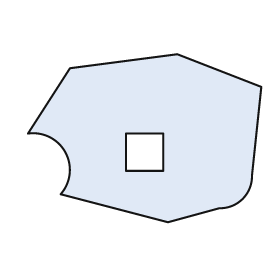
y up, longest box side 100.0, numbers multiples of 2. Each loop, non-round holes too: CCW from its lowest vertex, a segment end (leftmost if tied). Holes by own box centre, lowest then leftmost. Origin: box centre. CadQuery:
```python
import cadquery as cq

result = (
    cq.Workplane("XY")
    .moveTo(10.0, -36.0)
    .lineTo(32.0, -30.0)
    .threePointArc((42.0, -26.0), (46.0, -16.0))
    .lineTo(50.0, 22.0)
    .lineTo(14.0, 36.0)
    .lineTo(-32.0, 30.0)
    .lineTo(-50.0, 2.0)
    .threePointArc((-34.0, -6.0), (-36.0, -24.0))
    .close()
    .moveTo(-8.0, -14.0)
    .lineTo(8.0, -14.0)
    .lineTo(8.0, 2.0)
    .lineTo(-8.0, 2.0)
    .close()
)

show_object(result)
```